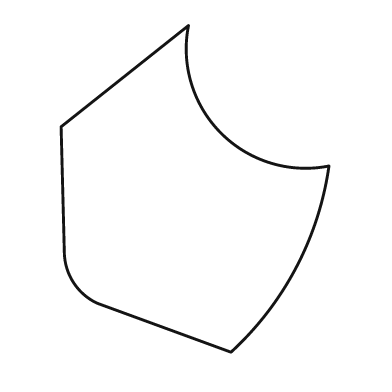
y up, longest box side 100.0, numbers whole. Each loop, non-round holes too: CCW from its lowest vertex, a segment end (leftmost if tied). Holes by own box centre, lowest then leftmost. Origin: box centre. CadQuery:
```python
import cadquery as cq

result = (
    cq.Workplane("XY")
    .moveTo(11.0, -50.0)
    .threePointArc((31.0, -24.0), (41.0, 7.0))
    .threePointArc((8.0, 17.0), (-2.0, 50.0))
    .lineTo(-41.0, 19.0)
    .lineTo(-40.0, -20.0)
    .threePointArc((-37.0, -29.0), (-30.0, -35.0))
    .close()
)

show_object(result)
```